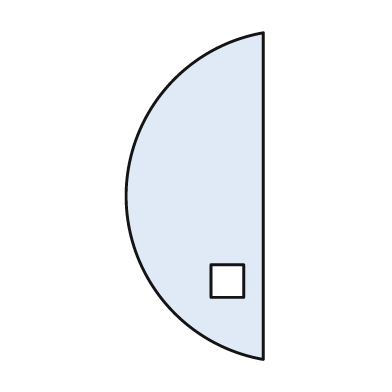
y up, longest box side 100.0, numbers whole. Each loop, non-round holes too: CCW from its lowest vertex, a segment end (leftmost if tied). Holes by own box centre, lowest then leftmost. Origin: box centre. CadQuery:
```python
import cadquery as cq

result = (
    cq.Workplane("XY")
    .moveTo(21.0, -50.0)
    .lineTo(21.0, 50.0)
    .threePointArc((-21.0, 0.0), (21.0, -50.0))
    .close()
    .moveTo(5.0, -31.0)
    .lineTo(15.0, -31.0)
    .lineTo(15.0, -21.0)
    .lineTo(5.0, -21.0)
    .close()
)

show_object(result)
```